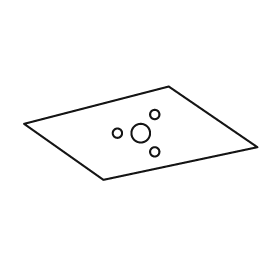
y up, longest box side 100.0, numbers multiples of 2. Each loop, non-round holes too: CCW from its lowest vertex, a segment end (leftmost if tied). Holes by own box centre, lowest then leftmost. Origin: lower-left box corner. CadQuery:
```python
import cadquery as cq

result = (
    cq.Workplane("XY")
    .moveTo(34.0, 0.0)
    .lineTo(100.0, 14.0)
    .lineTo(62.0, 40.0)
    .lineTo(0.0, 24.0)
    .close()
    .moveTo(56.0, 12.0)
    .circle(2.0)
    .moveTo(40.0, 20.0)
    .circle(2.0)
    .moveTo(50.0, 20.0)
    .circle(4.0)
    .moveTo(56.0, 28.0)
    .circle(2.0)
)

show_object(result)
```